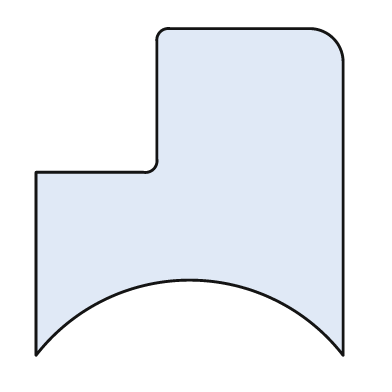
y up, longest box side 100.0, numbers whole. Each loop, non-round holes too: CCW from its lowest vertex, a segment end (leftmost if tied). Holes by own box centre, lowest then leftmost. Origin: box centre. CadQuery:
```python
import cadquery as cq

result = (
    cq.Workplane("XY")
    .moveTo(-47.0, -50.0)
    .threePointArc((0.0, -27.0), (47.0, -50.0))
    .lineTo(47.0, 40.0)
    .threePointArc((44.0, 47.0), (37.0, 50.0))
    .lineTo(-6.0, 50.0)
    .threePointArc((-9.0, 49.0), (-10.0, 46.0))
    .lineTo(-10.0, 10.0)
    .threePointArc((-11.0, 7.0), (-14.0, 6.0))
    .lineTo(-47.0, 6.0)
    .close()
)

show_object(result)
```